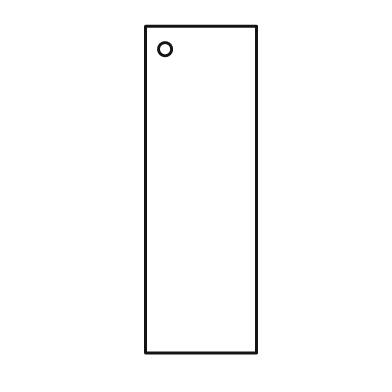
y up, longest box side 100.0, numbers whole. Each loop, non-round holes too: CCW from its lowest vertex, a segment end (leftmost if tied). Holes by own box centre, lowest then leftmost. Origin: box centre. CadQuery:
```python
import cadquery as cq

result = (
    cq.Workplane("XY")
    .moveTo(-17.0, -50.0)
    .lineTo(17.0, -50.0)
    .lineTo(17.0, 50.0)
    .lineTo(-17.0, 50.0)
    .close()
    .moveTo(-11.0, 43.0)
    .circle(2.0)
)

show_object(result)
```